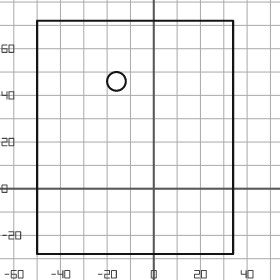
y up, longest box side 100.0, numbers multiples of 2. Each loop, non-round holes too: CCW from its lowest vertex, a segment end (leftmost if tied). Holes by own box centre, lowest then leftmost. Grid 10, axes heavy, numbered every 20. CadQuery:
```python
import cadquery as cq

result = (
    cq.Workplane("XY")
    .moveTo(-50.0, -28.0)
    .lineTo(34.0, -28.0)
    .lineTo(34.0, 72.0)
    .lineTo(-50.0, 72.0)
    .close()
    .moveTo(-16.0, 46.0)
    .circle(4.0)
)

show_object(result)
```